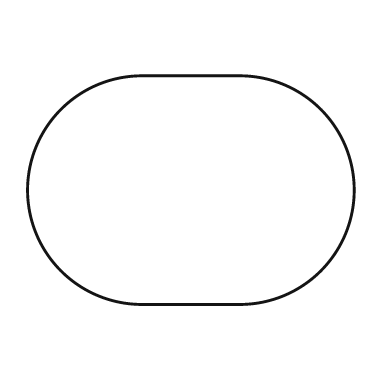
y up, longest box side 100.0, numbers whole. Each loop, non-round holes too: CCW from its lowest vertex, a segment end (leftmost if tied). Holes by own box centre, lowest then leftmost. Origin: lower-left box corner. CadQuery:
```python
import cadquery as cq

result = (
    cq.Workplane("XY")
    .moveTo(35.0, 0.0)
    .lineTo(65.0, 0.0)
    .threePointArc((100.0, 35.0), (65.0, 70.0))
    .lineTo(35.0, 70.0)
    .threePointArc((0.0, 35.0), (35.0, 0.0))
    .close()
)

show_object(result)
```